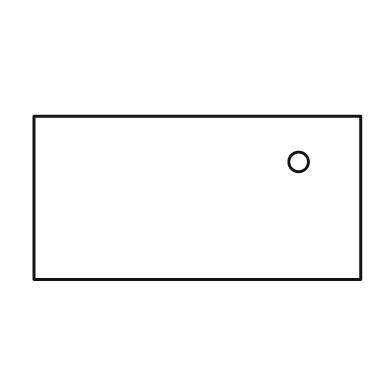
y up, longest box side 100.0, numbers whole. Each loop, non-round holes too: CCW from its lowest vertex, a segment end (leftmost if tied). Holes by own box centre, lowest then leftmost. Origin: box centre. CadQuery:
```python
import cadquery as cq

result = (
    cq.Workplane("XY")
    .moveTo(-50.0, -25.0)
    .lineTo(50.0, -25.0)
    .lineTo(50.0, 25.0)
    .lineTo(-50.0, 25.0)
    .close()
    .moveTo(31.0, 11.0)
    .circle(3.0)
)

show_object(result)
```